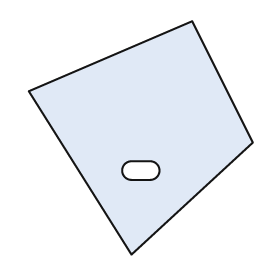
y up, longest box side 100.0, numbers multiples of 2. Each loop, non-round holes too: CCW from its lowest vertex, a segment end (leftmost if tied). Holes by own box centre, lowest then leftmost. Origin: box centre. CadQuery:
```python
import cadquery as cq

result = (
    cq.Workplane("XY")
    .moveTo(-4.0, -50.0)
    .lineTo(48.0, -2.0)
    .lineTo(22.0, 50.0)
    .lineTo(-48.0, 20.0)
    .close()
    .moveTo(-4.0, -18.0)
    .lineTo(4.0, -18.0)
    .threePointArc((8.0, -14.0), (4.0, -10.0))
    .lineTo(-4.0, -10.0)
    .threePointArc((-8.0, -14.0), (-4.0, -18.0))
    .close()
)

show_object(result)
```